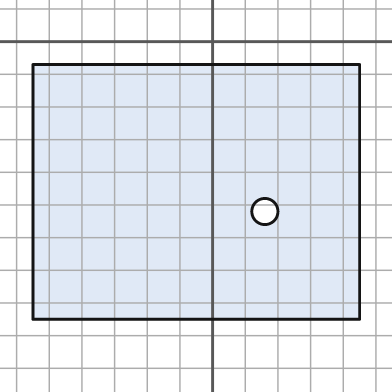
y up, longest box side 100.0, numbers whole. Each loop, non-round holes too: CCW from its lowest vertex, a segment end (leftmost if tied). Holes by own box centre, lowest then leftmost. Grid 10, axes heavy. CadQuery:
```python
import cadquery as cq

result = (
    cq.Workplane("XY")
    .moveTo(-55.0, -85.0)
    .lineTo(45.0, -85.0)
    .lineTo(45.0, -7.0)
    .lineTo(-55.0, -7.0)
    .close()
    .moveTo(16.0, -52.0)
    .circle(4.0)
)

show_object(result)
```